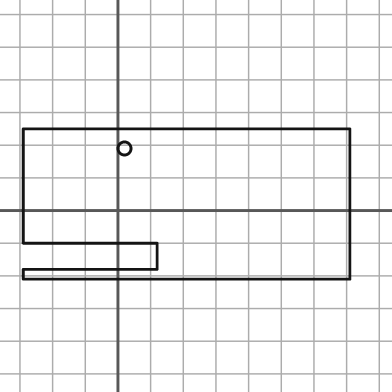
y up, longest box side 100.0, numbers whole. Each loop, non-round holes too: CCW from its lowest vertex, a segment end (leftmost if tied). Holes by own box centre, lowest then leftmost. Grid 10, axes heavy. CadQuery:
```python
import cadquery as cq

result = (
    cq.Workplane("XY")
    .moveTo(-29.0, -21.0)
    .lineTo(71.0, -21.0)
    .lineTo(71.0, 25.0)
    .lineTo(-29.0, 25.0)
    .lineTo(-29.0, -10.0)
    .lineTo(12.0, -10.0)
    .lineTo(12.0, -18.0)
    .lineTo(-29.0, -18.0)
    .close()
    .moveTo(2.0, 19.0)
    .circle(2.0)
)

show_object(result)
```